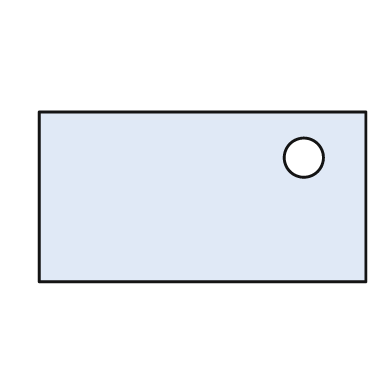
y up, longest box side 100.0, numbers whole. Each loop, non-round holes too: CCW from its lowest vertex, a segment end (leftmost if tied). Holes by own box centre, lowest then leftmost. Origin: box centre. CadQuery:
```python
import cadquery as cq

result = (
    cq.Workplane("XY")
    .moveTo(-50.0, -26.0)
    .lineTo(50.0, -26.0)
    .lineTo(50.0, 26.0)
    .lineTo(-50.0, 26.0)
    .close()
    .moveTo(31.0, 12.0)
    .circle(6.0)
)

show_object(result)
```